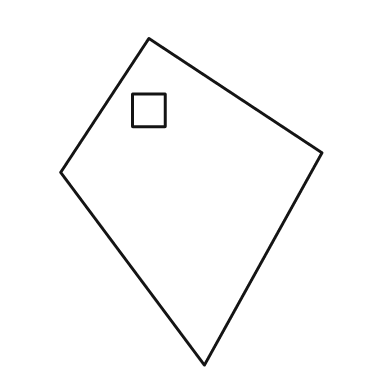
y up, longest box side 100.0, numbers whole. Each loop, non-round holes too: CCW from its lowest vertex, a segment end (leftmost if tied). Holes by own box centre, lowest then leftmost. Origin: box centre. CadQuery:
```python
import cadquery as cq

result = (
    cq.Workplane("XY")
    .moveTo(4.0, -50.0)
    .lineTo(40.0, 15.0)
    .lineTo(-13.0, 50.0)
    .lineTo(-40.0, 9.0)
    .close()
    .moveTo(-18.0, 23.0)
    .lineTo(-8.0, 23.0)
    .lineTo(-8.0, 33.0)
    .lineTo(-18.0, 33.0)
    .close()
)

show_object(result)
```